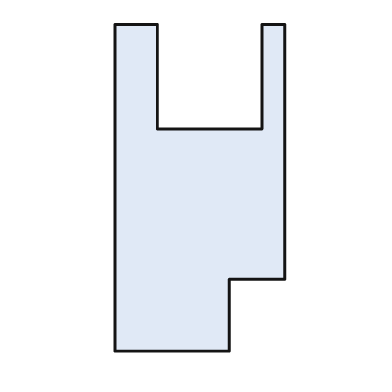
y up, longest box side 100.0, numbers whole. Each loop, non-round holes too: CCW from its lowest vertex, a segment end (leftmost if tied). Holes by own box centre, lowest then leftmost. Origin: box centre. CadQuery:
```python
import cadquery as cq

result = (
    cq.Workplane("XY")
    .moveTo(-26.0, -50.0)
    .lineTo(9.0, -50.0)
    .lineTo(9.0, -28.0)
    .lineTo(26.0, -28.0)
    .lineTo(26.0, 50.0)
    .lineTo(19.0, 50.0)
    .lineTo(19.0, 18.0)
    .lineTo(-13.0, 18.0)
    .lineTo(-13.0, 50.0)
    .lineTo(-26.0, 50.0)
    .close()
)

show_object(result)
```